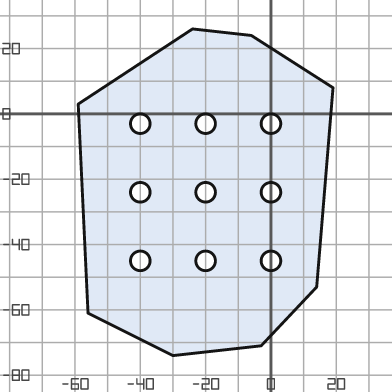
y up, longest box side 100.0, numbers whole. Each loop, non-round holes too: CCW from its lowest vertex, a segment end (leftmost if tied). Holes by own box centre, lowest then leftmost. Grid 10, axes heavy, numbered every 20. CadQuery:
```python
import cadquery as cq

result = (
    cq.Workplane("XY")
    .moveTo(-30.0, -74.0)
    .lineTo(-3.0, -71.0)
    .lineTo(14.0, -53.0)
    .lineTo(19.0, 8.0)
    .lineTo(-6.0, 24.0)
    .lineTo(-24.0, 26.0)
    .lineTo(-59.0, 3.0)
    .lineTo(-56.0, -61.0)
    .close()
    .moveTo(-40.0, -45.0)
    .circle(3.0)
    .moveTo(-20.0, -45.0)
    .circle(3.0)
    .moveTo(0.0, -45.0)
    .circle(3.0)
    .moveTo(-40.0, -24.0)
    .circle(3.0)
    .moveTo(-20.0, -24.0)
    .circle(3.0)
    .moveTo(0.0, -24.0)
    .circle(3.0)
    .moveTo(-40.0, -3.0)
    .circle(3.0)
    .moveTo(-20.0, -3.0)
    .circle(3.0)
    .moveTo(0.0, -3.0)
    .circle(3.0)
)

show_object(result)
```